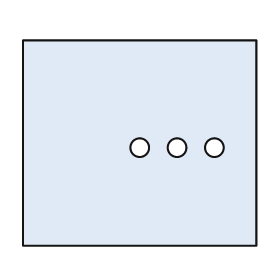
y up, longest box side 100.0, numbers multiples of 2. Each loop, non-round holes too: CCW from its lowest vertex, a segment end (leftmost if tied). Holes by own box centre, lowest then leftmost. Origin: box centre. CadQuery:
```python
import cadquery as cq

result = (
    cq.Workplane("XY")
    .moveTo(-50.0, -44.0)
    .lineTo(50.0, -44.0)
    .lineTo(50.0, 44.0)
    .lineTo(-50.0, 44.0)
    .close()
    .moveTo(0.0, -2.0)
    .circle(4.0)
    .moveTo(16.0, -2.0)
    .circle(4.0)
    .moveTo(32.0, -2.0)
    .circle(4.0)
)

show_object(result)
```